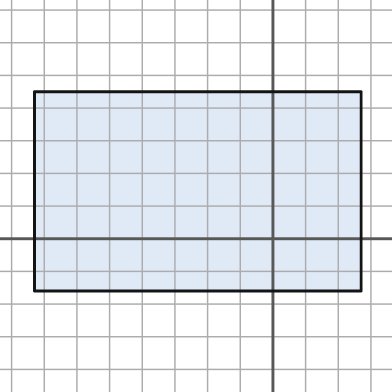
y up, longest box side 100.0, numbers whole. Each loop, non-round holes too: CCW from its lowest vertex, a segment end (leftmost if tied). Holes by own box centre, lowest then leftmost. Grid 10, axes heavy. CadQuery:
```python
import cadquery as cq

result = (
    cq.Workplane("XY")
    .moveTo(-73.0, -16.0)
    .lineTo(27.0, -16.0)
    .lineTo(27.0, 45.0)
    .lineTo(-73.0, 45.0)
    .close()
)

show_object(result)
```